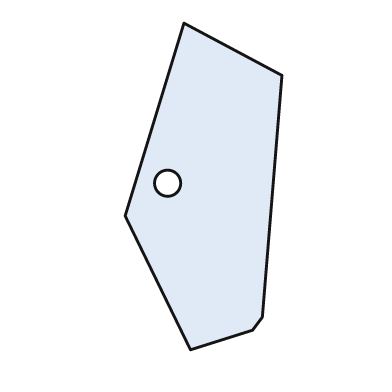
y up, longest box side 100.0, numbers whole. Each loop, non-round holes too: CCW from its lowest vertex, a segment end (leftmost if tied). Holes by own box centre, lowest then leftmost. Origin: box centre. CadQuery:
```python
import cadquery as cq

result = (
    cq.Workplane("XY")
    .moveTo(-4.0, -50.0)
    .lineTo(15.0, -44.0)
    .lineTo(18.0, -40.0)
    .lineTo(24.0, 34.0)
    .lineTo(-6.0, 50.0)
    .lineTo(-24.0, -9.0)
    .close()
    .moveTo(-11.0, 1.0)
    .circle(4.0)
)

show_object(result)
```